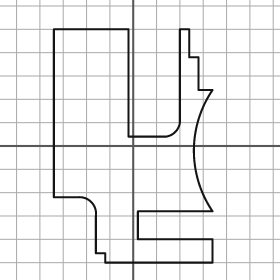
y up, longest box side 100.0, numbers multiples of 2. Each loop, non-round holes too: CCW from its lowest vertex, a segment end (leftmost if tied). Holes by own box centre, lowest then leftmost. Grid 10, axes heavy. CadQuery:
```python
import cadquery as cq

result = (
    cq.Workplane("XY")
    .moveTo(-12.0, -50.0)
    .lineTo(34.0, -50.0)
    .lineTo(34.0, -40.0)
    .lineTo(2.0, -40.0)
    .lineTo(2.0, -28.0)
    .lineTo(34.0, -28.0)
    .threePointArc((26.0, -2.0), (34.0, 24.0))
    .lineTo(28.0, 24.0)
    .lineTo(28.0, 38.0)
    .lineTo(24.0, 38.0)
    .lineTo(24.0, 50.0)
    .lineTo(20.0, 50.0)
    .lineTo(20.0, 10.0)
    .threePointArc((18.0, 6.0), (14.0, 4.0))
    .lineTo(-2.0, 4.0)
    .lineTo(-2.0, 50.0)
    .lineTo(-34.0, 50.0)
    .lineTo(-34.0, -22.0)
    .lineTo(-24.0, -22.0)
    .threePointArc((-18.0, -24.0), (-16.0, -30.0))
    .lineTo(-16.0, -46.0)
    .lineTo(-12.0, -46.0)
    .close()
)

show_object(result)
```